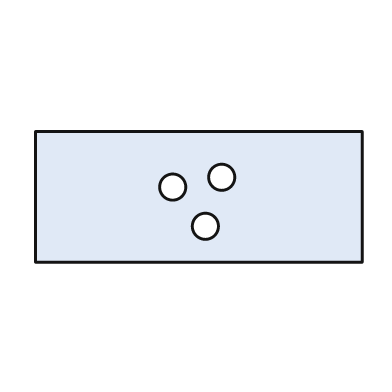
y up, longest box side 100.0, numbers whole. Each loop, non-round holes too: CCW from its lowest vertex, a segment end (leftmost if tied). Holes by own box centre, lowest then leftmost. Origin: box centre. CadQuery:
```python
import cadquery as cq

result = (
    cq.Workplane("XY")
    .moveTo(-50.0, -20.0)
    .lineTo(50.0, -20.0)
    .lineTo(50.0, 20.0)
    .lineTo(-50.0, 20.0)
    .close()
    .moveTo(2.0, -9.0)
    .circle(4.0)
    .moveTo(-8.0, 3.0)
    .circle(4.0)
    .moveTo(7.0, 6.0)
    .circle(4.0)
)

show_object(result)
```